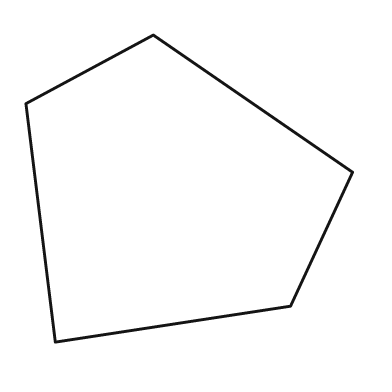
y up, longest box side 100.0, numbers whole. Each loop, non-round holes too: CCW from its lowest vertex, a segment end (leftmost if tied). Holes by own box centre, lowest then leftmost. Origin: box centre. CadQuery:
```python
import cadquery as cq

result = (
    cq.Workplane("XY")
    .moveTo(-41.0, -47.0)
    .lineTo(31.0, -36.0)
    .lineTo(50.0, 5.0)
    .lineTo(-11.0, 47.0)
    .lineTo(-50.0, 26.0)
    .close()
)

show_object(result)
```